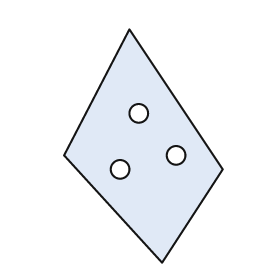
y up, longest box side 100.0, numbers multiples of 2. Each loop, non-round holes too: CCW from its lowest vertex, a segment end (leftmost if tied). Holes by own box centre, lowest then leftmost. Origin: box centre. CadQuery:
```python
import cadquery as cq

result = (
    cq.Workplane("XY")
    .moveTo(8.0, -50.0)
    .lineTo(34.0, -10.0)
    .lineTo(-6.0, 50.0)
    .lineTo(-34.0, -4.0)
    .close()
    .moveTo(-10.0, -10.0)
    .circle(4.0)
    .moveTo(14.0, -4.0)
    .circle(4.0)
    .moveTo(-2.0, 14.0)
    .circle(4.0)
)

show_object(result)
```